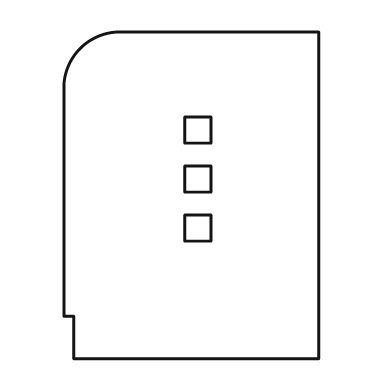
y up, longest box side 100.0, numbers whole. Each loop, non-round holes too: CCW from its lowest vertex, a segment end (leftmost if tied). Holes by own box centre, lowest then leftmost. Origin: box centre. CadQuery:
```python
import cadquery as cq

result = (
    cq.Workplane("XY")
    .moveTo(-36.0, -50.0)
    .lineTo(39.0, -50.0)
    .lineTo(39.0, 50.0)
    .lineTo(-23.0, 50.0)
    .threePointArc((-34.0, 45.0), (-39.0, 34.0))
    .lineTo(-39.0, -37.0)
    .lineTo(-36.0, -37.0)
    .close()
    .moveTo(-2.0, -14.0)
    .lineTo(6.0, -14.0)
    .lineTo(6.0, -6.0)
    .lineTo(-2.0, -6.0)
    .close()
    .moveTo(-2.0, 1.0)
    .lineTo(6.0, 1.0)
    .lineTo(6.0, 9.0)
    .lineTo(-2.0, 9.0)
    .close()
    .moveTo(-2.0, 16.0)
    .lineTo(6.0, 16.0)
    .lineTo(6.0, 24.0)
    .lineTo(-2.0, 24.0)
    .close()
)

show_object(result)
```